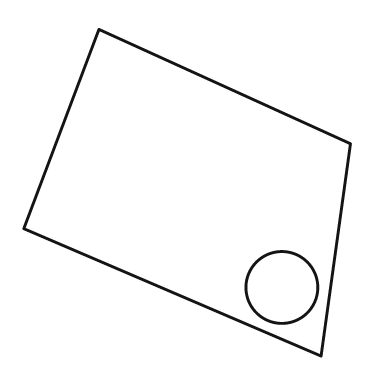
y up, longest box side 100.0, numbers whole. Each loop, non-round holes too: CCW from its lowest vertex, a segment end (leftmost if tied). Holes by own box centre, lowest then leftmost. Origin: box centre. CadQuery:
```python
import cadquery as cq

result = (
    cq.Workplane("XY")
    .moveTo(41.0, -50.0)
    .lineTo(50.0, 15.0)
    .lineTo(-27.0, 50.0)
    .lineTo(-50.0, -11.0)
    .close()
    .moveTo(29.0, -29.0)
    .circle(11.0)
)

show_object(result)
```